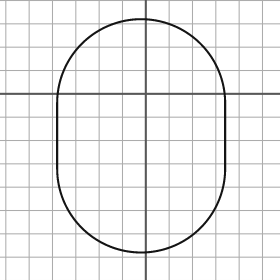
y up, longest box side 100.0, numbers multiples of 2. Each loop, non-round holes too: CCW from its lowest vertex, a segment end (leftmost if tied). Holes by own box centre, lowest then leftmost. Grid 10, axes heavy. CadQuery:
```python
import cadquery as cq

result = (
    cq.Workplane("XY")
    .moveTo(-38.0, -32.0)
    .threePointArc((-2.0, -68.0), (34.0, -32.0))
    .lineTo(34.0, -4.0)
    .threePointArc((-2.0, 32.0), (-38.0, -4.0))
    .close()
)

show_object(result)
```